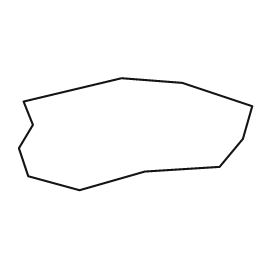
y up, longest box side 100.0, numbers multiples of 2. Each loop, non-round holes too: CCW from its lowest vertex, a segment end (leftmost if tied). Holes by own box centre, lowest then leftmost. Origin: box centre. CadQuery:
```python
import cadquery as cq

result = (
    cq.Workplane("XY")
    .moveTo(-24.0, -24.0)
    .lineTo(4.0, -16.0)
    .lineTo(36.0, -14.0)
    .lineTo(46.0, -2.0)
    .lineTo(50.0, 12.0)
    .lineTo(20.0, 22.0)
    .lineTo(-6.0, 24.0)
    .lineTo(-48.0, 14.0)
    .lineTo(-44.0, 4.0)
    .lineTo(-50.0, -6.0)
    .lineTo(-46.0, -18.0)
    .close()
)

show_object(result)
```